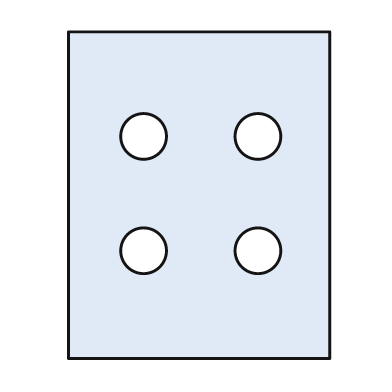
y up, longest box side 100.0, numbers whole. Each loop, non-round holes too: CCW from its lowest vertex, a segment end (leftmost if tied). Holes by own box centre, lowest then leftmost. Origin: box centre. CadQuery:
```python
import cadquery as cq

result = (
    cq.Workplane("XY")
    .moveTo(-40.0, -50.0)
    .lineTo(40.0, -50.0)
    .lineTo(40.0, 50.0)
    .lineTo(-40.0, 50.0)
    .close()
    .moveTo(-17.0, -17.0)
    .circle(7.0)
    .moveTo(18.0, -17.0)
    .circle(7.0)
    .moveTo(-17.0, 18.0)
    .circle(7.0)
    .moveTo(18.0, 18.0)
    .circle(7.0)
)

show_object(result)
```